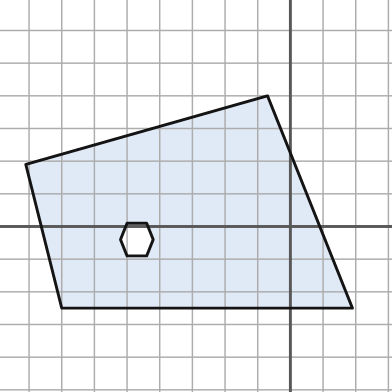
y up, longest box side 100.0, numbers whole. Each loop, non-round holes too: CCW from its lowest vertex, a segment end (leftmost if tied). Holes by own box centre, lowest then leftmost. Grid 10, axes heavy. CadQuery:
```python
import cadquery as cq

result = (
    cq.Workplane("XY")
    .moveTo(-70.0, -25.0)
    .lineTo(19.0, -25.0)
    .lineTo(-7.0, 40.0)
    .lineTo(-81.0, 19.0)
    .close()
    .moveTo(-50.0, -9.0)
    .lineTo(-44.0, -9.0)
    .lineTo(-42.0, -4.0)
    .lineTo(-44.0, 1.0)
    .lineTo(-50.0, 1.0)
    .lineTo(-52.0, -4.0)
    .close()
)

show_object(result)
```